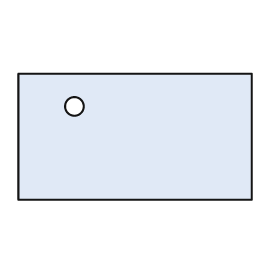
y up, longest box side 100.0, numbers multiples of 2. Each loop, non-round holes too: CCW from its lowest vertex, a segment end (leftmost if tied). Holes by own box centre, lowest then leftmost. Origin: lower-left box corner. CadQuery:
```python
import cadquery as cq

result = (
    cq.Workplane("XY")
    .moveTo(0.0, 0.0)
    .lineTo(100.0, 0.0)
    .lineTo(100.0, 54.0)
    .lineTo(0.0, 54.0)
    .close()
    .moveTo(24.0, 40.0)
    .circle(4.0)
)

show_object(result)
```